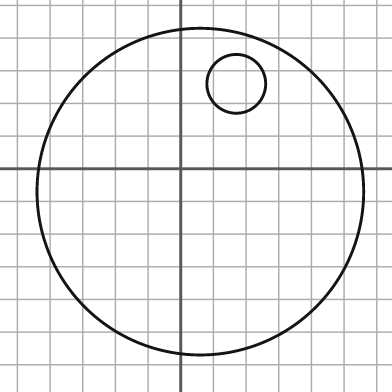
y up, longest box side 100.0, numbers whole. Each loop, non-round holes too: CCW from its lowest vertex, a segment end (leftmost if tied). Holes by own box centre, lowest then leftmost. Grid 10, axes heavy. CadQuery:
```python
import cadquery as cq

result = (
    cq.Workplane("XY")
    .moveTo(6.0, -7.0)
    .circle(50.0)
    .moveTo(17.0, 26.0)
    .circle(9.0)
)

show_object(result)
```